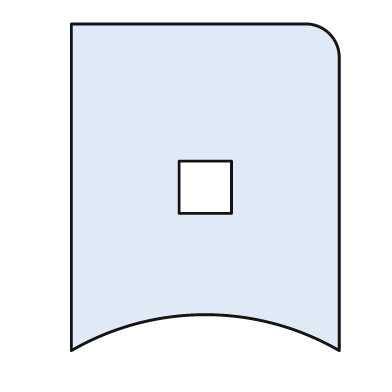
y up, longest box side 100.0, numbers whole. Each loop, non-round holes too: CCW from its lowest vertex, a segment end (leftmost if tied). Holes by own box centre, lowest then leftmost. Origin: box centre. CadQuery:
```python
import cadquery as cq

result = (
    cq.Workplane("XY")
    .moveTo(-41.0, -50.0)
    .threePointArc((0.0, -39.0), (41.0, -50.0))
    .lineTo(41.0, 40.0)
    .threePointArc((38.0, 47.0), (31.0, 50.0))
    .lineTo(-41.0, 50.0)
    .close()
    .moveTo(-8.0, -8.0)
    .lineTo(8.0, -8.0)
    .lineTo(8.0, 8.0)
    .lineTo(-8.0, 8.0)
    .close()
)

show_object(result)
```